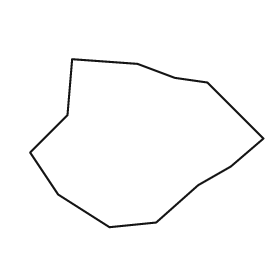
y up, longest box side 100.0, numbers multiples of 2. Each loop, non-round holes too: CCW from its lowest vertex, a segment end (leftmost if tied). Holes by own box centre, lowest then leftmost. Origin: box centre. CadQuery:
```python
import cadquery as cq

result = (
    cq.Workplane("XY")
    .moveTo(-16.0, -36.0)
    .lineTo(4.0, -34.0)
    .lineTo(22.0, -18.0)
    .lineTo(36.0, -10.0)
    .lineTo(50.0, 2.0)
    .lineTo(26.0, 26.0)
    .lineTo(12.0, 28.0)
    .lineTo(-4.0, 34.0)
    .lineTo(-32.0, 36.0)
    .lineTo(-34.0, 12.0)
    .lineTo(-50.0, -4.0)
    .lineTo(-38.0, -22.0)
    .close()
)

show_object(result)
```